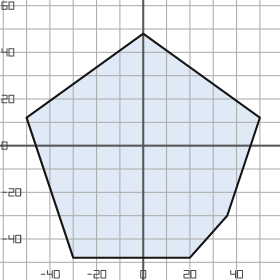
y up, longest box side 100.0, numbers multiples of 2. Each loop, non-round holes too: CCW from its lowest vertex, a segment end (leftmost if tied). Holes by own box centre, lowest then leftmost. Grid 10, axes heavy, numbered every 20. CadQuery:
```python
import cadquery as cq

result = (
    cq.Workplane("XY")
    .moveTo(-30.0, -48.0)
    .lineTo(20.0, -48.0)
    .lineTo(36.0, -30.0)
    .lineTo(50.0, 12.0)
    .lineTo(0.0, 48.0)
    .lineTo(-50.0, 12.0)
    .close()
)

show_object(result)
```